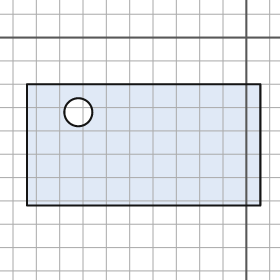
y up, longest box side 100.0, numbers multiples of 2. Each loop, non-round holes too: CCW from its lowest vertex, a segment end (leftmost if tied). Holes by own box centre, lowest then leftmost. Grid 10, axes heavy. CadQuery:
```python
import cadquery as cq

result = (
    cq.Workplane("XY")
    .moveTo(-94.0, -72.0)
    .lineTo(6.0, -72.0)
    .lineTo(6.0, -20.0)
    .lineTo(-94.0, -20.0)
    .close()
    .moveTo(-72.0, -32.0)
    .circle(6.0)
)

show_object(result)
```